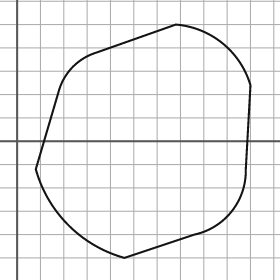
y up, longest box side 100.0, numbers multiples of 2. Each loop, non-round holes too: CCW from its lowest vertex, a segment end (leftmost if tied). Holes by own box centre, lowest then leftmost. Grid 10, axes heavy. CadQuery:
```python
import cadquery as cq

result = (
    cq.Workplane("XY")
    .moveTo(46.0, -50.0)
    .lineTo(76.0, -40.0)
    .threePointArc((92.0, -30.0), (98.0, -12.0))
    .lineTo(100.0, 24.0)
    .threePointArc((88.0, 42.0), (68.0, 50.0))
    .lineTo(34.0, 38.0)
    .threePointArc((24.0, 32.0), (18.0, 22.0))
    .lineTo(8.0, -12.0)
    .threePointArc((22.0, -36.0), (46.0, -50.0))
    .close()
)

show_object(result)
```